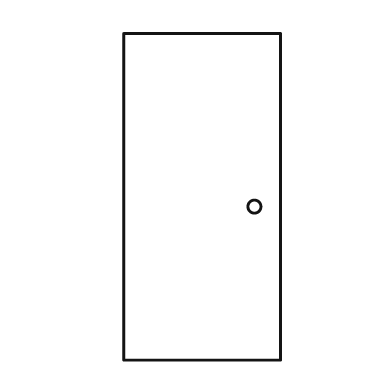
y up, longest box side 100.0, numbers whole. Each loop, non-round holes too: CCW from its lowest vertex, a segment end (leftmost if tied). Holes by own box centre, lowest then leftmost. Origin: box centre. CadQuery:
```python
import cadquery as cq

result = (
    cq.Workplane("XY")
    .moveTo(-24.0, -50.0)
    .lineTo(24.0, -50.0)
    .lineTo(24.0, 50.0)
    .lineTo(-24.0, 50.0)
    .close()
    .moveTo(16.0, -3.0)
    .circle(2.0)
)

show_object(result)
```